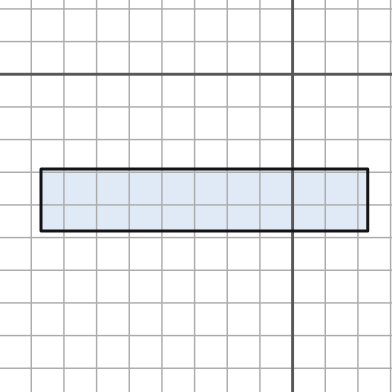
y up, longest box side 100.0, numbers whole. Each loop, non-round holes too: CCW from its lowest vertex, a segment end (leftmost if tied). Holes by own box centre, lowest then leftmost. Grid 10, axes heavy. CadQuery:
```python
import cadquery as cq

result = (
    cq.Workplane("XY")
    .moveTo(-77.0, -48.0)
    .lineTo(23.0, -48.0)
    .lineTo(23.0, -29.0)
    .lineTo(-77.0, -29.0)
    .close()
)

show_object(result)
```